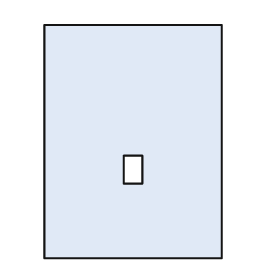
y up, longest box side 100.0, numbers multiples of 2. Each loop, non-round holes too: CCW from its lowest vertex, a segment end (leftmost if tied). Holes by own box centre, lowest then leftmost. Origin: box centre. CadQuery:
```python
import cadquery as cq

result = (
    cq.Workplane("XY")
    .moveTo(-38.0, -50.0)
    .lineTo(38.0, -50.0)
    .lineTo(38.0, 50.0)
    .lineTo(-38.0, 50.0)
    .close()
    .moveTo(-4.0, -18.0)
    .lineTo(4.0, -18.0)
    .lineTo(4.0, -6.0)
    .lineTo(-4.0, -6.0)
    .close()
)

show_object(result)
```